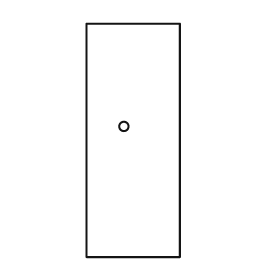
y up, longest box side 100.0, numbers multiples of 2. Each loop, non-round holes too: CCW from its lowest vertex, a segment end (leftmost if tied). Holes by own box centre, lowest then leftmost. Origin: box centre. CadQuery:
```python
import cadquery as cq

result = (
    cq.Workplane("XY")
    .moveTo(-20.0, -50.0)
    .lineTo(20.0, -50.0)
    .lineTo(20.0, 50.0)
    .lineTo(-20.0, 50.0)
    .close()
    .moveTo(-4.0, 6.0)
    .circle(2.0)
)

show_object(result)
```